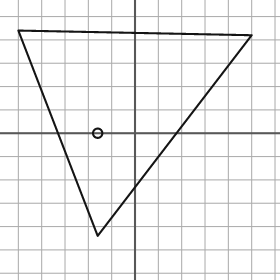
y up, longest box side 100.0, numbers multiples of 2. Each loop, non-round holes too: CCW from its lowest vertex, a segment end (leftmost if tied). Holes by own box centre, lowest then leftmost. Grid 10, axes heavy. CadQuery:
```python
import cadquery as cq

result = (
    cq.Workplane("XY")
    .moveTo(-16.0, -44.0)
    .lineTo(50.0, 42.0)
    .lineTo(-50.0, 44.0)
    .close()
    .moveTo(-16.0, 0.0)
    .circle(2.0)
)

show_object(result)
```